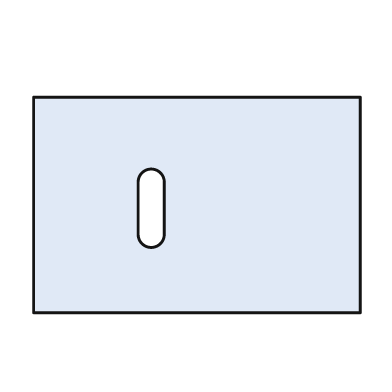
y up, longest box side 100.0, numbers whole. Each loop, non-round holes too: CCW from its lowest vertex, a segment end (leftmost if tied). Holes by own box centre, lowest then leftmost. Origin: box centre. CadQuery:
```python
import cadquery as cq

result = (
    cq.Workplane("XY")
    .moveTo(-50.0, -33.0)
    .lineTo(50.0, -33.0)
    .lineTo(50.0, 33.0)
    .lineTo(-50.0, 33.0)
    .close()
    .moveTo(-18.0, -9.0)
    .threePointArc((-14.0, -13.0), (-10.0, -9.0))
    .lineTo(-10.0, 7.0)
    .threePointArc((-14.0, 11.0), (-18.0, 7.0))
    .close()
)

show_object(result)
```